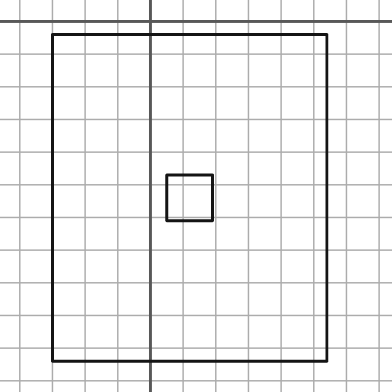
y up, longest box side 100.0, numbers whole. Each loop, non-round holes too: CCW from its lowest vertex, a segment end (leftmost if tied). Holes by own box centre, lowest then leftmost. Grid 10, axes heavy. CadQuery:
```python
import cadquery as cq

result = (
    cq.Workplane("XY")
    .moveTo(-30.0, -104.0)
    .lineTo(54.0, -104.0)
    .lineTo(54.0, -4.0)
    .lineTo(-30.0, -4.0)
    .close()
    .moveTo(5.0, -61.0)
    .lineTo(19.0, -61.0)
    .lineTo(19.0, -47.0)
    .lineTo(5.0, -47.0)
    .close()
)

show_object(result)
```